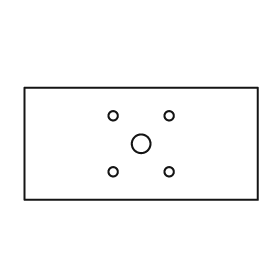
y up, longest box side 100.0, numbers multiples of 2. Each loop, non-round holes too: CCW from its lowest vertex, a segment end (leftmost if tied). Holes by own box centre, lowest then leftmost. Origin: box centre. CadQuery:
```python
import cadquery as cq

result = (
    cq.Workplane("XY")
    .moveTo(-50.0, -24.0)
    .lineTo(50.0, -24.0)
    .lineTo(50.0, 24.0)
    .lineTo(-50.0, 24.0)
    .close()
    .moveTo(-12.0, -12.0)
    .circle(2.0)
    .moveTo(12.0, -12.0)
    .circle(2.0)
    .moveTo(0.0, 0.0)
    .circle(4.0)
    .moveTo(-12.0, 12.0)
    .circle(2.0)
    .moveTo(12.0, 12.0)
    .circle(2.0)
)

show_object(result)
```